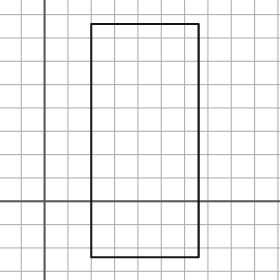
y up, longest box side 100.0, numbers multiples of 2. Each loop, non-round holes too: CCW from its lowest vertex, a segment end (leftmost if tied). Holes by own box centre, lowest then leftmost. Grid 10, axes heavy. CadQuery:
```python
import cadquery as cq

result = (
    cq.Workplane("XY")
    .moveTo(20.0, -24.0)
    .lineTo(66.0, -24.0)
    .lineTo(66.0, 76.0)
    .lineTo(20.0, 76.0)
    .close()
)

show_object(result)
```